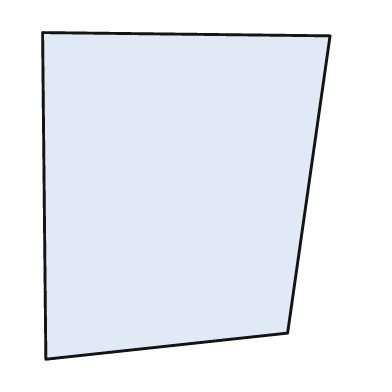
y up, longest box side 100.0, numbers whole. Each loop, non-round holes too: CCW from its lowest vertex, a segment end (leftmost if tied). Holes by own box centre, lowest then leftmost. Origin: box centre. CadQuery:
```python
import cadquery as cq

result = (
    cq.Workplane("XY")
    .moveTo(-43.0, -50.0)
    .lineTo(31.0, -42.0)
    .lineTo(44.0, 49.0)
    .lineTo(-44.0, 50.0)
    .close()
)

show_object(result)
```